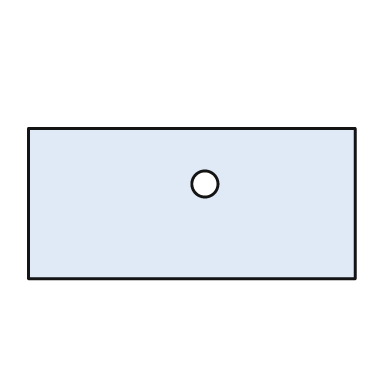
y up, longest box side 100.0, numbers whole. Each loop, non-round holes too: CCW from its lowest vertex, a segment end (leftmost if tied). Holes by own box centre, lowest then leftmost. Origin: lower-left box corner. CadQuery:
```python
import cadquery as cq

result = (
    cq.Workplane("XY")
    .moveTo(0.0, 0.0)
    .lineTo(100.0, 0.0)
    .lineTo(100.0, 46.0)
    .lineTo(0.0, 46.0)
    .close()
    .moveTo(54.0, 29.0)
    .circle(4.0)
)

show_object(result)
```